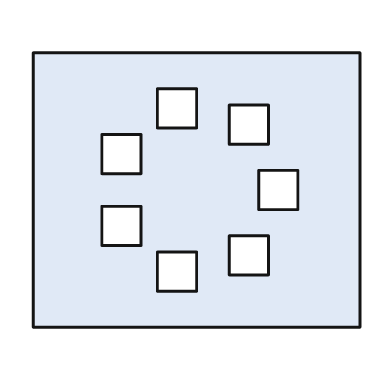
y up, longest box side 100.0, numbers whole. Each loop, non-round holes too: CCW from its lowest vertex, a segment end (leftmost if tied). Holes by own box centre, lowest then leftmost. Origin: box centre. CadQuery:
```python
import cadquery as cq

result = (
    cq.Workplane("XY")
    .moveTo(-50.0, -42.0)
    .lineTo(50.0, -42.0)
    .lineTo(50.0, 42.0)
    .lineTo(-50.0, 42.0)
    .close()
    .moveTo(-12.0, -31.0)
    .lineTo(0.0, -31.0)
    .lineTo(0.0, -19.0)
    .lineTo(-12.0, -19.0)
    .close()
    .moveTo(10.0, -26.0)
    .lineTo(22.0, -26.0)
    .lineTo(22.0, -14.0)
    .lineTo(10.0, -14.0)
    .close()
    .moveTo(-29.0, -17.0)
    .lineTo(-17.0, -17.0)
    .lineTo(-17.0, -5.0)
    .lineTo(-29.0, -5.0)
    .close()
    .moveTo(19.0, -6.0)
    .lineTo(31.0, -6.0)
    .lineTo(31.0, 6.0)
    .lineTo(19.0, 6.0)
    .close()
    .moveTo(-29.0, 5.0)
    .lineTo(-17.0, 5.0)
    .lineTo(-17.0, 17.0)
    .lineTo(-29.0, 17.0)
    .close()
    .moveTo(10.0, 14.0)
    .lineTo(22.0, 14.0)
    .lineTo(22.0, 26.0)
    .lineTo(10.0, 26.0)
    .close()
    .moveTo(-12.0, 19.0)
    .lineTo(0.0, 19.0)
    .lineTo(0.0, 31.0)
    .lineTo(-12.0, 31.0)
    .close()
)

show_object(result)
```